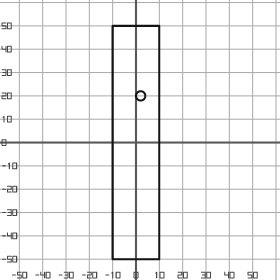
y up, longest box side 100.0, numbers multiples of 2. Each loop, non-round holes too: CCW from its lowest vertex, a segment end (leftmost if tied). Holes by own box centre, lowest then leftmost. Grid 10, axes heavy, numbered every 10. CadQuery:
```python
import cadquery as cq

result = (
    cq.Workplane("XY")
    .moveTo(-10.0, -50.0)
    .lineTo(10.0, -50.0)
    .lineTo(10.0, 50.0)
    .lineTo(-10.0, 50.0)
    .close()
    .moveTo(2.0, 20.0)
    .circle(2.0)
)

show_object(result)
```